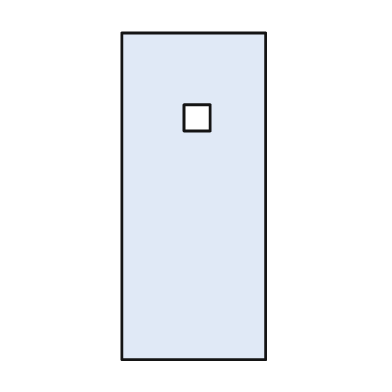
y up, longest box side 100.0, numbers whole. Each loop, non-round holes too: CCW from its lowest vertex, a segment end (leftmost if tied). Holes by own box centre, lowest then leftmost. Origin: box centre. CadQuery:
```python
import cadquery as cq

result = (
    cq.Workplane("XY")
    .moveTo(-22.0, -50.0)
    .lineTo(22.0, -50.0)
    .lineTo(22.0, 50.0)
    .lineTo(-22.0, 50.0)
    .close()
    .moveTo(-3.0, 20.0)
    .lineTo(5.0, 20.0)
    .lineTo(5.0, 28.0)
    .lineTo(-3.0, 28.0)
    .close()
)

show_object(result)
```